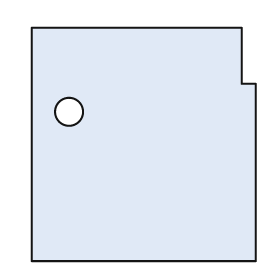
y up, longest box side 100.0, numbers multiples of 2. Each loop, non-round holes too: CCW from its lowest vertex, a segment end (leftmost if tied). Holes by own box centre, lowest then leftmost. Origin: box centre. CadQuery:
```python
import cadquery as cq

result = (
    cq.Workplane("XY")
    .moveTo(-48.0, -50.0)
    .lineTo(48.0, -50.0)
    .lineTo(48.0, 26.0)
    .lineTo(42.0, 26.0)
    .lineTo(42.0, 50.0)
    .lineTo(-48.0, 50.0)
    .close()
    .moveTo(-32.0, 14.0)
    .circle(6.0)
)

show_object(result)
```